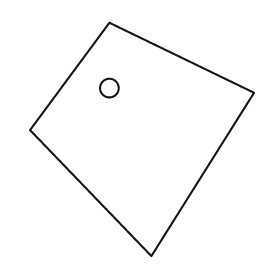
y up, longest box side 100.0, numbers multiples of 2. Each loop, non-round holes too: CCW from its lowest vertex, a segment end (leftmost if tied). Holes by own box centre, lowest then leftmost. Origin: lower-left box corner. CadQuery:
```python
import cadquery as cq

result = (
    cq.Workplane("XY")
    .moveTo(52.0, 0.0)
    .lineTo(96.0, 70.0)
    .lineTo(34.0, 100.0)
    .lineTo(0.0, 54.0)
    .close()
    .moveTo(34.0, 72.0)
    .circle(4.0)
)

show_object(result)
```